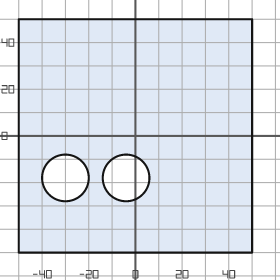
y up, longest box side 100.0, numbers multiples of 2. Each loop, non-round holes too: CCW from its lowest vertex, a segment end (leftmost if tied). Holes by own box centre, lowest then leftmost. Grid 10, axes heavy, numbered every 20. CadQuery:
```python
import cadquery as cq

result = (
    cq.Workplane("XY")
    .moveTo(-50.0, -50.0)
    .lineTo(50.0, -50.0)
    .lineTo(50.0, 50.0)
    .lineTo(-50.0, 50.0)
    .close()
    .moveTo(-30.0, -18.0)
    .circle(10.0)
    .moveTo(-4.0, -18.0)
    .circle(10.0)
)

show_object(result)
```